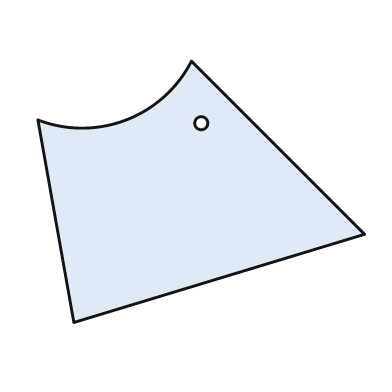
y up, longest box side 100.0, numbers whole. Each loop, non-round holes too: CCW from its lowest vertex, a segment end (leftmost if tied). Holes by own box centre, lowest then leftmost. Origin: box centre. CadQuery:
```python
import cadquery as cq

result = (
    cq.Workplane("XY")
    .moveTo(-39.0, -40.0)
    .lineTo(50.0, -13.0)
    .lineTo(-3.0, 40.0)
    .threePointArc((-23.0, 22.0), (-50.0, 22.0))
    .close()
    .moveTo(0.0, 21.0)
    .circle(2.0)
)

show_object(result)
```